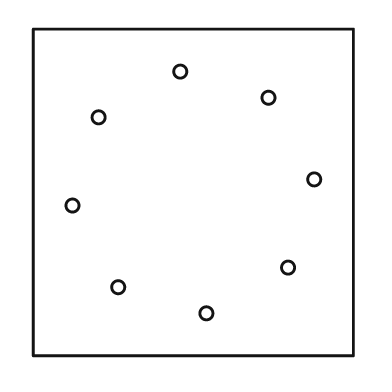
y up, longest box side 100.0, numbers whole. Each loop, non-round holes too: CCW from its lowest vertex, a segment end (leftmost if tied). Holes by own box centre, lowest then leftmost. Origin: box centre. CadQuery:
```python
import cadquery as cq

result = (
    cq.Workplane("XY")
    .moveTo(-49.0, -50.0)
    .lineTo(49.0, -50.0)
    .lineTo(49.0, 50.0)
    .lineTo(-49.0, 50.0)
    .close()
    .moveTo(4.0, -37.0)
    .circle(2.0)
    .moveTo(-23.0, -29.0)
    .circle(2.0)
    .moveTo(29.0, -23.0)
    .circle(2.0)
    .moveTo(-37.0, -4.0)
    .circle(2.0)
    .moveTo(37.0, 4.0)
    .circle(2.0)
    .moveTo(-29.0, 23.0)
    .circle(2.0)
    .moveTo(23.0, 29.0)
    .circle(2.0)
    .moveTo(-4.0, 37.0)
    .circle(2.0)
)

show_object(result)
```